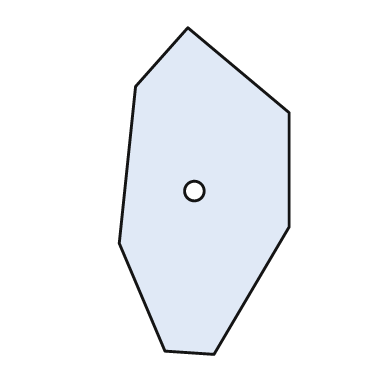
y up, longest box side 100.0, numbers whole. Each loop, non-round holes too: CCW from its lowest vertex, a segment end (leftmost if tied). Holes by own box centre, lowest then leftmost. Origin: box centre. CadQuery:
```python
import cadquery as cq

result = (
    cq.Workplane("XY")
    .moveTo(3.0, -50.0)
    .lineTo(26.0, -11.0)
    .lineTo(26.0, 24.0)
    .lineTo(-5.0, 50.0)
    .lineTo(-21.0, 32.0)
    .lineTo(-26.0, -16.0)
    .lineTo(-12.0, -49.0)
    .close()
    .moveTo(-3.0, 0.0)
    .circle(3.0)
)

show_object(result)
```